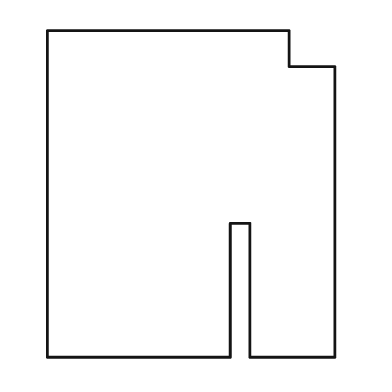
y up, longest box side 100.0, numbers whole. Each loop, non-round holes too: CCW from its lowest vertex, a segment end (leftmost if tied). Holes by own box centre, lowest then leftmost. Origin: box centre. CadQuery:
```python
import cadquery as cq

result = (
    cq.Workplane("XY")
    .moveTo(-44.0, -50.0)
    .lineTo(12.0, -50.0)
    .lineTo(12.0, -9.0)
    .lineTo(18.0, -9.0)
    .lineTo(18.0, -50.0)
    .lineTo(44.0, -50.0)
    .lineTo(44.0, 39.0)
    .lineTo(30.0, 39.0)
    .lineTo(30.0, 50.0)
    .lineTo(-44.0, 50.0)
    .close()
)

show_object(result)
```